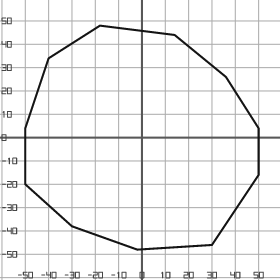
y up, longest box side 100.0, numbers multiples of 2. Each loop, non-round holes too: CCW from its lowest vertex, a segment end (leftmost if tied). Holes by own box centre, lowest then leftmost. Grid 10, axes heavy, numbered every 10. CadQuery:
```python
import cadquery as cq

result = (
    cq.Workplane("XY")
    .moveTo(-2.0, -48.0)
    .lineTo(30.0, -46.0)
    .lineTo(50.0, -16.0)
    .lineTo(50.0, 4.0)
    .lineTo(36.0, 26.0)
    .lineTo(14.0, 44.0)
    .lineTo(-18.0, 48.0)
    .lineTo(-40.0, 34.0)
    .lineTo(-50.0, 4.0)
    .lineTo(-50.0, -20.0)
    .lineTo(-30.0, -38.0)
    .close()
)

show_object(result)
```